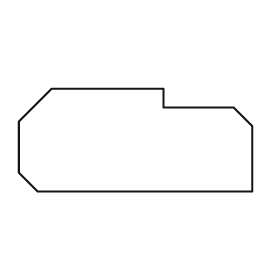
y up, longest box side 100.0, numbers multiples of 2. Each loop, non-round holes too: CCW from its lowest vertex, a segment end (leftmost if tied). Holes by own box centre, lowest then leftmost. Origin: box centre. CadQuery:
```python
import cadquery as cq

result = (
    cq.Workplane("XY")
    .moveTo(-42.0, -22.0)
    .lineTo(50.0, -22.0)
    .lineTo(50.0, 6.0)
    .lineTo(42.0, 14.0)
    .lineTo(12.0, 14.0)
    .lineTo(12.0, 22.0)
    .lineTo(-36.0, 22.0)
    .lineTo(-50.0, 8.0)
    .lineTo(-50.0, -14.0)
    .close()
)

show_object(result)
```